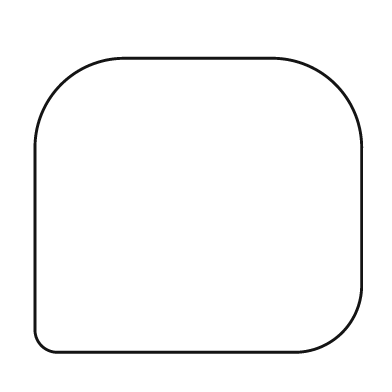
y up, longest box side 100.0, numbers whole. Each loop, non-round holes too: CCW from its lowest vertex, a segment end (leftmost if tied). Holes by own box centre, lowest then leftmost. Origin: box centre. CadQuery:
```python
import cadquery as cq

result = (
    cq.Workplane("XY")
    .moveTo(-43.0, -45.0)
    .lineTo(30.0, -45.0)
    .threePointArc((44.0, -39.0), (50.0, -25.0))
    .lineTo(50.0, 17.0)
    .threePointArc((42.0, 37.0), (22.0, 45.0))
    .lineTo(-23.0, 45.0)
    .threePointArc((-42.0, 37.0), (-50.0, 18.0))
    .lineTo(-50.0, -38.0)
    .threePointArc((-48.0, -43.0), (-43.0, -45.0))
    .close()
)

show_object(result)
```